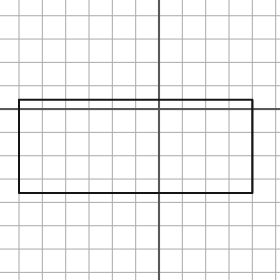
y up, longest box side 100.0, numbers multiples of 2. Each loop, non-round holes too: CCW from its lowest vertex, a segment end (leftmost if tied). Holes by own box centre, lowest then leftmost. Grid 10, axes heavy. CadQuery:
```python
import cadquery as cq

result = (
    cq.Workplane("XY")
    .moveTo(-60.0, -36.0)
    .lineTo(40.0, -36.0)
    .lineTo(40.0, 4.0)
    .lineTo(-60.0, 4.0)
    .close()
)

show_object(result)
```